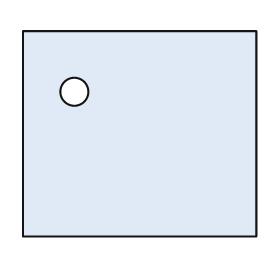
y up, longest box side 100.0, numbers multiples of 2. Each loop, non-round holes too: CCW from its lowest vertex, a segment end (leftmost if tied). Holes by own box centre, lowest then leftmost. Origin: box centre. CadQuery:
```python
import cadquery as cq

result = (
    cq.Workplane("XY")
    .moveTo(-50.0, -44.0)
    .lineTo(50.0, -44.0)
    .lineTo(50.0, 44.0)
    .lineTo(-50.0, 44.0)
    .close()
    .moveTo(-28.0, 18.0)
    .circle(6.0)
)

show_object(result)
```